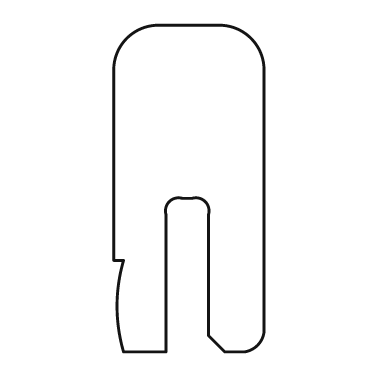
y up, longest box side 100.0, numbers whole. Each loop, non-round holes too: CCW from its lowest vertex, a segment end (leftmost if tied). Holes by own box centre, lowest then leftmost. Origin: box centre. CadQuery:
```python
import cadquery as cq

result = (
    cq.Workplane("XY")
    .moveTo(-20.0, -50.0)
    .lineTo(-7.0, -50.0)
    .lineTo(-7.0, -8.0)
    .threePointArc((-6.0, -4.0), (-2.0, -3.0))
    .lineTo(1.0, -3.0)
    .threePointArc((5.0, -4.0), (6.0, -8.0))
    .lineTo(6.0, -45.0)
    .lineTo(11.0, -50.0)
    .lineTo(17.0, -50.0)
    .threePointArc((21.0, -48.0), (23.0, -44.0))
    .lineTo(23.0, 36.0)
    .threePointArc((19.0, 46.0), (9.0, 50.0))
    .lineTo(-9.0, 50.0)
    .threePointArc((-19.0, 46.0), (-23.0, 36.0))
    .lineTo(-23.0, -22.0)
    .lineTo(-20.0, -22.0)
    .threePointArc((-22.0, -36.0), (-20.0, -50.0))
    .close()
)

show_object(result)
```